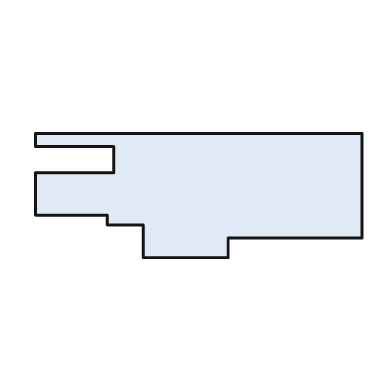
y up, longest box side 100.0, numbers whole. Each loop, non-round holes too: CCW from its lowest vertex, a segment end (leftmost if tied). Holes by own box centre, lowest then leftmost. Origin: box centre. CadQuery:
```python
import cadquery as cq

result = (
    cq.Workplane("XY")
    .moveTo(-17.0, -19.0)
    .lineTo(9.0, -19.0)
    .lineTo(9.0, -13.0)
    .lineTo(50.0, -13.0)
    .lineTo(50.0, 19.0)
    .lineTo(-50.0, 19.0)
    .lineTo(-50.0, 15.0)
    .lineTo(-26.0, 15.0)
    .lineTo(-26.0, 7.0)
    .lineTo(-50.0, 7.0)
    .lineTo(-50.0, -6.0)
    .lineTo(-28.0, -6.0)
    .lineTo(-28.0, -9.0)
    .lineTo(-17.0, -9.0)
    .close()
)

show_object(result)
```